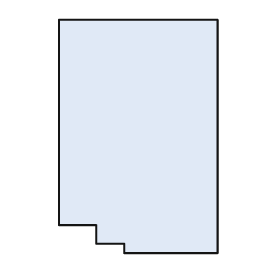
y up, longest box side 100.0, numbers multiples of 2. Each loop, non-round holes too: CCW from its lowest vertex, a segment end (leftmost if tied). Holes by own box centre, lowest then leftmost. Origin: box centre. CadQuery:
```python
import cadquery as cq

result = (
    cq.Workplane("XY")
    .moveTo(-6.0, -50.0)
    .lineTo(34.0, -50.0)
    .lineTo(34.0, 50.0)
    .lineTo(-34.0, 50.0)
    .lineTo(-34.0, -38.0)
    .lineTo(-18.0, -38.0)
    .lineTo(-18.0, -46.0)
    .lineTo(-6.0, -46.0)
    .close()
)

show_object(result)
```